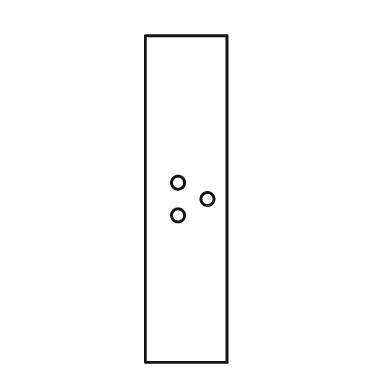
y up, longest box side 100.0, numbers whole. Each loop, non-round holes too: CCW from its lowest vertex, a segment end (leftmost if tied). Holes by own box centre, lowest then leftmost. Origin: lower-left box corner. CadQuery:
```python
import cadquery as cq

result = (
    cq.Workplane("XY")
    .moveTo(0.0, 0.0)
    .lineTo(25.0, 0.0)
    .lineTo(25.0, 100.0)
    .lineTo(0.0, 100.0)
    .close()
    .moveTo(10.0, 45.0)
    .circle(2.0)
    .moveTo(19.0, 50.0)
    .circle(2.0)
    .moveTo(10.0, 55.0)
    .circle(2.0)
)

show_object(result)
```